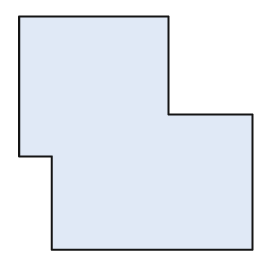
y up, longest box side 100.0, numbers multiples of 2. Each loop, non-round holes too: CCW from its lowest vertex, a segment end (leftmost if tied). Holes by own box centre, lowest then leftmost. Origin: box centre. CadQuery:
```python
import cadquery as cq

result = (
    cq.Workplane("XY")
    .moveTo(-36.0, -50.0)
    .lineTo(50.0, -50.0)
    .lineTo(50.0, 8.0)
    .lineTo(14.0, 8.0)
    .lineTo(14.0, 50.0)
    .lineTo(-50.0, 50.0)
    .lineTo(-50.0, -10.0)
    .lineTo(-36.0, -10.0)
    .close()
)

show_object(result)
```